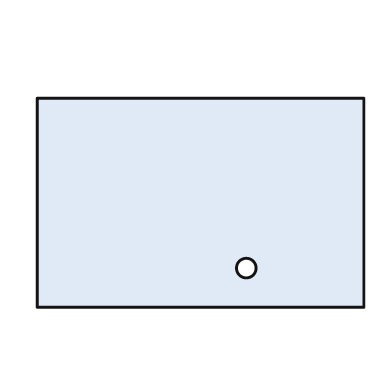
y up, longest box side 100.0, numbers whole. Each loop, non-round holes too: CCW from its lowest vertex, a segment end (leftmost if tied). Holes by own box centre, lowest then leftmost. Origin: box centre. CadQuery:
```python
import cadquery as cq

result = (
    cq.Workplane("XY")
    .moveTo(-50.0, -32.0)
    .lineTo(50.0, -32.0)
    .lineTo(50.0, 32.0)
    .lineTo(-50.0, 32.0)
    .close()
    .moveTo(14.0, -20.0)
    .circle(3.0)
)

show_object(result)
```